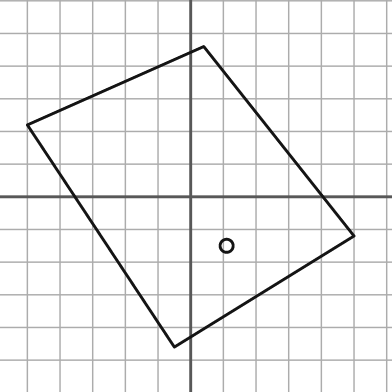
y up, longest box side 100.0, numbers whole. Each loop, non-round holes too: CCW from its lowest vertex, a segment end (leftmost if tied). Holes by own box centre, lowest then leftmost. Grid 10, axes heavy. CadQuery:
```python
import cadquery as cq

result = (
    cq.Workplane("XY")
    .moveTo(-5.0, -46.0)
    .lineTo(50.0, -12.0)
    .lineTo(4.0, 46.0)
    .lineTo(-50.0, 22.0)
    .close()
    .moveTo(11.0, -15.0)
    .circle(2.0)
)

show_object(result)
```